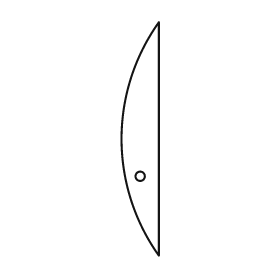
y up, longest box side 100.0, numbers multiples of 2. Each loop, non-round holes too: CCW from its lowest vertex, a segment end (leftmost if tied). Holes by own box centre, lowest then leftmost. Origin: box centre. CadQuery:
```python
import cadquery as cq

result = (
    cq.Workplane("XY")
    .moveTo(8.0, -50.0)
    .lineTo(8.0, 50.0)
    .threePointArc((-8.0, 0.0), (8.0, -50.0))
    .close()
    .moveTo(0.0, -16.0)
    .circle(2.0)
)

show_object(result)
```